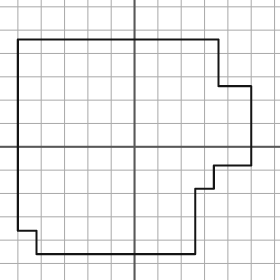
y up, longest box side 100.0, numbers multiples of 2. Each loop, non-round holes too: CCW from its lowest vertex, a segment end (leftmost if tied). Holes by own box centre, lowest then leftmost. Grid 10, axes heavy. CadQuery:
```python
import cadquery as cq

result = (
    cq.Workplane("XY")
    .moveTo(-42.0, -46.0)
    .lineTo(26.0, -46.0)
    .lineTo(26.0, -18.0)
    .lineTo(34.0, -18.0)
    .lineTo(34.0, -8.0)
    .lineTo(50.0, -8.0)
    .lineTo(50.0, 26.0)
    .lineTo(36.0, 26.0)
    .lineTo(36.0, 46.0)
    .lineTo(-50.0, 46.0)
    .lineTo(-50.0, -36.0)
    .lineTo(-42.0, -36.0)
    .close()
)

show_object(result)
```